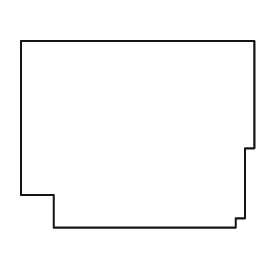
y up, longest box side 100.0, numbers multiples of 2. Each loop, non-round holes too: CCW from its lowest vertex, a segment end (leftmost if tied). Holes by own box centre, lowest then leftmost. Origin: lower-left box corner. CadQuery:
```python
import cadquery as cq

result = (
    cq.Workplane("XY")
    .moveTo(14.0, 0.0)
    .lineTo(92.0, 0.0)
    .lineTo(92.0, 4.0)
    .lineTo(96.0, 4.0)
    .lineTo(96.0, 34.0)
    .lineTo(100.0, 34.0)
    .lineTo(100.0, 80.0)
    .lineTo(0.0, 80.0)
    .lineTo(0.0, 14.0)
    .lineTo(14.0, 14.0)
    .close()
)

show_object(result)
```